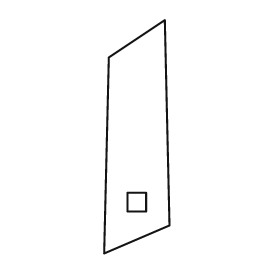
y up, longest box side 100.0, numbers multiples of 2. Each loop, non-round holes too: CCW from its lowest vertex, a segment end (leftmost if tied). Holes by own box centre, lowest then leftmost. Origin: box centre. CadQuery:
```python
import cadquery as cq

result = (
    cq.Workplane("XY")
    .moveTo(-14.0, -50.0)
    .lineTo(14.0, -38.0)
    .lineTo(12.0, 50.0)
    .lineTo(-12.0, 34.0)
    .close()
    .moveTo(-4.0, -32.0)
    .lineTo(4.0, -32.0)
    .lineTo(4.0, -24.0)
    .lineTo(-4.0, -24.0)
    .close()
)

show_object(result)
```